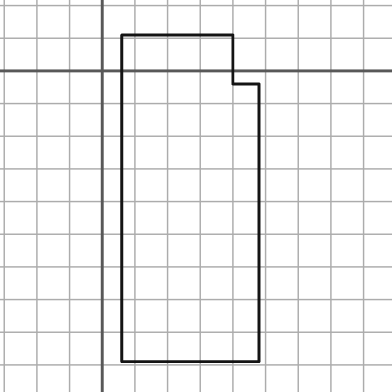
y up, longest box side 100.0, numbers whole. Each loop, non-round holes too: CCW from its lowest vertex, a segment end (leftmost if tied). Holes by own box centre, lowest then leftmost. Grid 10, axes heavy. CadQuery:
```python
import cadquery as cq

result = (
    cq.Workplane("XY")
    .moveTo(6.0, -89.0)
    .lineTo(48.0, -89.0)
    .lineTo(48.0, -4.0)
    .lineTo(40.0, -4.0)
    .lineTo(40.0, 11.0)
    .lineTo(6.0, 11.0)
    .close()
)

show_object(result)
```